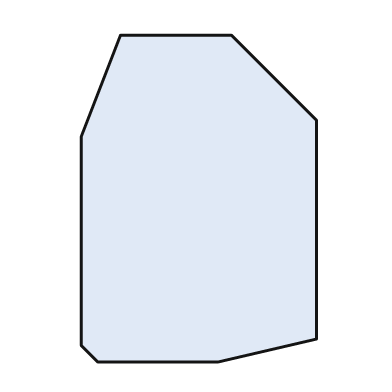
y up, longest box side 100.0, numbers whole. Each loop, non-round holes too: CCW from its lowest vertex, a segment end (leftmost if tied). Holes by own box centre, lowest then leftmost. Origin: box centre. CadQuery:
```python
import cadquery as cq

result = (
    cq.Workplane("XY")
    .moveTo(-31.0, -50.0)
    .lineTo(6.0, -50.0)
    .lineTo(36.0, -43.0)
    .lineTo(36.0, 24.0)
    .lineTo(10.0, 50.0)
    .lineTo(-24.0, 50.0)
    .lineTo(-36.0, 19.0)
    .lineTo(-36.0, -45.0)
    .close()
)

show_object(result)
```